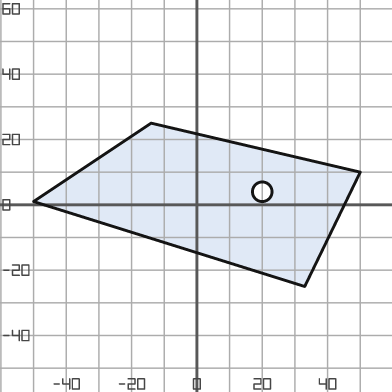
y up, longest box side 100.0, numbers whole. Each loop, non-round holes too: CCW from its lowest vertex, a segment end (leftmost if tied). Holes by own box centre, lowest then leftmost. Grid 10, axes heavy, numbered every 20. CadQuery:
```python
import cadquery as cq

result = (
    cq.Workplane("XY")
    .moveTo(33.0, -25.0)
    .lineTo(50.0, 10.0)
    .lineTo(-14.0, 25.0)
    .lineTo(-50.0, 1.0)
    .close()
    .moveTo(20.0, 4.0)
    .circle(3.0)
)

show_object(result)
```